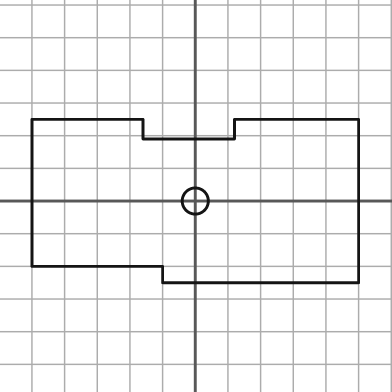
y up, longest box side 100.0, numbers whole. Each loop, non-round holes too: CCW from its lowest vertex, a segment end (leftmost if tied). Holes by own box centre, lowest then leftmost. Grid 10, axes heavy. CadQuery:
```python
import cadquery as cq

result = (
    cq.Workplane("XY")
    .moveTo(-10.0, -25.0)
    .lineTo(50.0, -25.0)
    .lineTo(50.0, 25.0)
    .lineTo(12.0, 25.0)
    .lineTo(12.0, 19.0)
    .lineTo(-16.0, 19.0)
    .lineTo(-16.0, 25.0)
    .lineTo(-50.0, 25.0)
    .lineTo(-50.0, -20.0)
    .lineTo(-10.0, -20.0)
    .close()
    .moveTo(0.0, 0.0)
    .circle(4.0)
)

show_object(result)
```